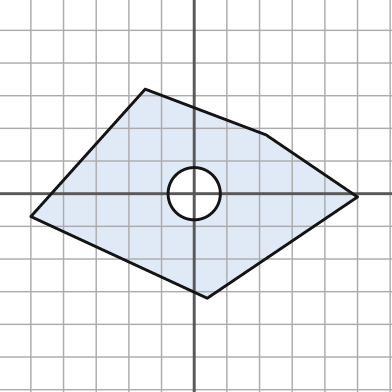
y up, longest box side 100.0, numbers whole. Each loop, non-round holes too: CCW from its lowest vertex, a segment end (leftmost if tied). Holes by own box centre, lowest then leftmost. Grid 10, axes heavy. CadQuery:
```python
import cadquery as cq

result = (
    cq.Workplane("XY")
    .moveTo(4.0, -32.0)
    .lineTo(50.0, -1.0)
    .lineTo(22.0, 18.0)
    .lineTo(-15.0, 32.0)
    .lineTo(-50.0, -7.0)
    .close()
    .moveTo(0.0, 0.0)
    .circle(8.0)
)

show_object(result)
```